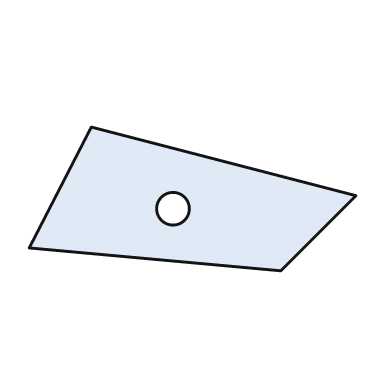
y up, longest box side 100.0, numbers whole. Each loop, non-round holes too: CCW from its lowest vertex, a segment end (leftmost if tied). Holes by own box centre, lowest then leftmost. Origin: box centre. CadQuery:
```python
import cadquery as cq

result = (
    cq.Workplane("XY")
    .moveTo(27.0, -22.0)
    .lineTo(50.0, 1.0)
    .lineTo(-31.0, 22.0)
    .lineTo(-50.0, -15.0)
    .close()
    .moveTo(-6.0, -3.0)
    .circle(5.0)
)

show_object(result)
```